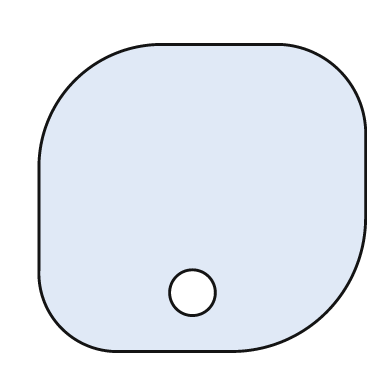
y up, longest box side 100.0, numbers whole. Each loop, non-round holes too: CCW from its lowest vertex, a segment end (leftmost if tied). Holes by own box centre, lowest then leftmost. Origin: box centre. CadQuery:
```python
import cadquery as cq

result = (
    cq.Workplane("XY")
    .moveTo(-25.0, -47.0)
    .lineTo(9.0, -47.0)
    .threePointArc((38.0, -35.0), (50.0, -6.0))
    .lineTo(50.0, 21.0)
    .threePointArc((42.0, 39.0), (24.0, 47.0))
    .lineTo(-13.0, 47.0)
    .threePointArc((-39.0, 36.0), (-50.0, 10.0))
    .lineTo(-50.0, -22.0)
    .threePointArc((-43.0, -40.0), (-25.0, -47.0))
    .close()
    .moveTo(-3.0, -29.0)
    .circle(7.0)
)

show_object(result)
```